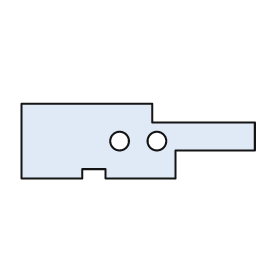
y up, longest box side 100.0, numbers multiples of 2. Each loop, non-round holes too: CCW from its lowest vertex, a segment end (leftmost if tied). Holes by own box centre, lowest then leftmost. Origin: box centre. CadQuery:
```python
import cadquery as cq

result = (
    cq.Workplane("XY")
    .moveTo(-50.0, -16.0)
    .lineTo(-24.0, -16.0)
    .lineTo(-24.0, -12.0)
    .lineTo(-14.0, -12.0)
    .lineTo(-14.0, -16.0)
    .lineTo(16.0, -16.0)
    .lineTo(16.0, -4.0)
    .lineTo(50.0, -4.0)
    .lineTo(50.0, 8.0)
    .lineTo(6.0, 8.0)
    .lineTo(6.0, 16.0)
    .lineTo(-50.0, 16.0)
    .close()
    .moveTo(-8.0, 0.0)
    .circle(4.0)
    .moveTo(8.0, 0.0)
    .circle(4.0)
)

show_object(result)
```